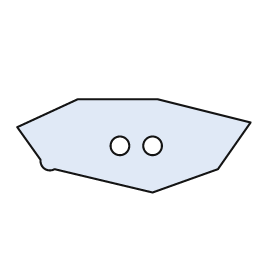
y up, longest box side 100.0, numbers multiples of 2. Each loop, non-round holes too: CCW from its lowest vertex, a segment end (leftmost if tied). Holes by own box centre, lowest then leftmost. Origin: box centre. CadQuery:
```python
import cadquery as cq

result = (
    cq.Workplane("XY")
    .moveTo(8.0, -20.0)
    .lineTo(36.0, -10.0)
    .lineTo(50.0, 10.0)
    .lineTo(10.0, 20.0)
    .lineTo(-24.0, 20.0)
    .lineTo(-50.0, 8.0)
    .lineTo(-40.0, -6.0)
    .threePointArc((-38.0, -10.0), (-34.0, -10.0))
    .close()
    .moveTo(-6.0, 0.0)
    .circle(4.0)
    .moveTo(8.0, 0.0)
    .circle(4.0)
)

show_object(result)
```